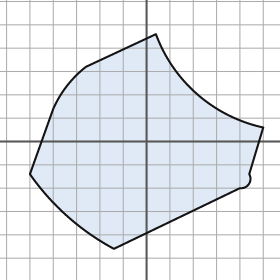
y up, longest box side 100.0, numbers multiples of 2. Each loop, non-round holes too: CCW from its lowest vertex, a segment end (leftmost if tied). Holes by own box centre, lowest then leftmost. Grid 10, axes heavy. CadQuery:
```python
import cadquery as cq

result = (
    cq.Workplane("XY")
    .moveTo(-14.0, -46.0)
    .lineTo(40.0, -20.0)
    .threePointArc((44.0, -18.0), (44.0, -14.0))
    .lineTo(50.0, 6.0)
    .threePointArc((22.0, 20.0), (4.0, 46.0))
    .lineTo(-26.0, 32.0)
    .threePointArc((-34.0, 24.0), (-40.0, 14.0))
    .lineTo(-50.0, -14.0)
    .threePointArc((-34.0, -32.0), (-14.0, -46.0))
    .close()
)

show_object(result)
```